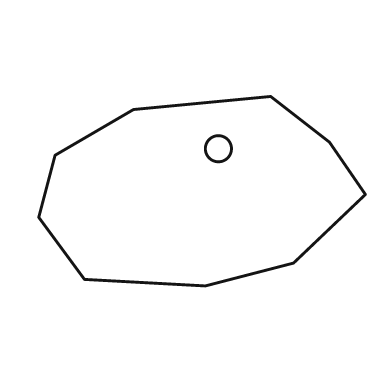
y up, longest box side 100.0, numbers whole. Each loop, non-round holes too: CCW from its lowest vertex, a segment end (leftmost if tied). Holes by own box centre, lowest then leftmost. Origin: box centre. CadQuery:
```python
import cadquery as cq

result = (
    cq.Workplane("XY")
    .moveTo(1.0, -29.0)
    .lineTo(28.0, -22.0)
    .lineTo(50.0, -1.0)
    .lineTo(39.0, 15.0)
    .lineTo(21.0, 29.0)
    .lineTo(-21.0, 25.0)
    .lineTo(-45.0, 11.0)
    .lineTo(-50.0, -8.0)
    .lineTo(-36.0, -27.0)
    .close()
    .moveTo(5.0, 13.0)
    .circle(4.0)
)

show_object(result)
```